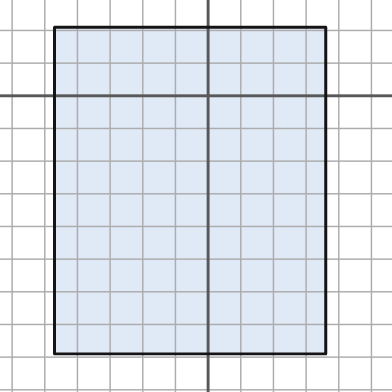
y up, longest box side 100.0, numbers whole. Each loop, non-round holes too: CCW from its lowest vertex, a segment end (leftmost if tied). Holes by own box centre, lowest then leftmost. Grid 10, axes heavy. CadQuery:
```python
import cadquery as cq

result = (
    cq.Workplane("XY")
    .moveTo(-47.0, -79.0)
    .lineTo(36.0, -79.0)
    .lineTo(36.0, 21.0)
    .lineTo(-47.0, 21.0)
    .close()
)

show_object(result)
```